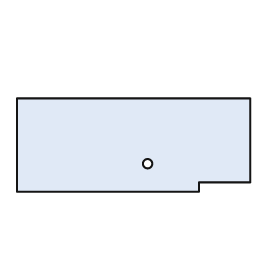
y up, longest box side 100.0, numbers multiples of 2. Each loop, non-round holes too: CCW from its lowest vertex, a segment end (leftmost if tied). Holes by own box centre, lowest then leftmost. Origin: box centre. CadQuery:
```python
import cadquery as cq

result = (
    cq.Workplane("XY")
    .moveTo(-50.0, -20.0)
    .lineTo(28.0, -20.0)
    .lineTo(28.0, -16.0)
    .lineTo(50.0, -16.0)
    .lineTo(50.0, 20.0)
    .lineTo(-50.0, 20.0)
    .close()
    .moveTo(6.0, -8.0)
    .circle(2.0)
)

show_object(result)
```